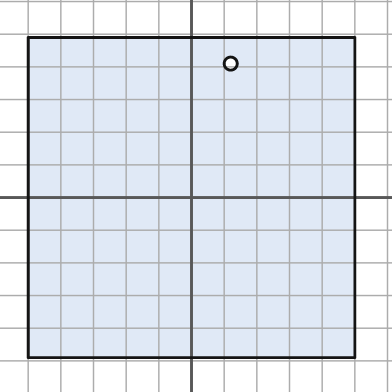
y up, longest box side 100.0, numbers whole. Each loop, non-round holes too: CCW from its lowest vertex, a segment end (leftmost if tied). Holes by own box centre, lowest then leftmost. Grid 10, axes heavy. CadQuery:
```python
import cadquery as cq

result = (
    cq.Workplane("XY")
    .moveTo(-50.0, -49.0)
    .lineTo(50.0, -49.0)
    .lineTo(50.0, 49.0)
    .lineTo(-50.0, 49.0)
    .close()
    .moveTo(12.0, 41.0)
    .circle(2.0)
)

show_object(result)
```